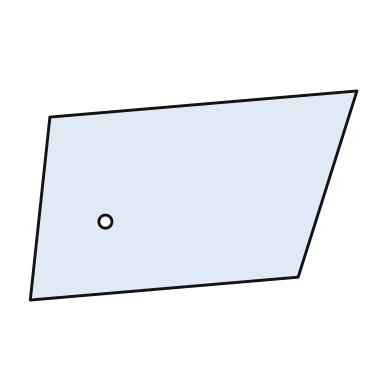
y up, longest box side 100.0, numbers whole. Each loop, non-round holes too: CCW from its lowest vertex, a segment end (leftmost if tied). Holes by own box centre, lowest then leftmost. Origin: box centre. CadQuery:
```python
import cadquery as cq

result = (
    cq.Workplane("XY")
    .moveTo(-50.0, -32.0)
    .lineTo(32.0, -25.0)
    .lineTo(50.0, 32.0)
    .lineTo(-44.0, 24.0)
    .close()
    .moveTo(-27.0, -8.0)
    .circle(2.0)
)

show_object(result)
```